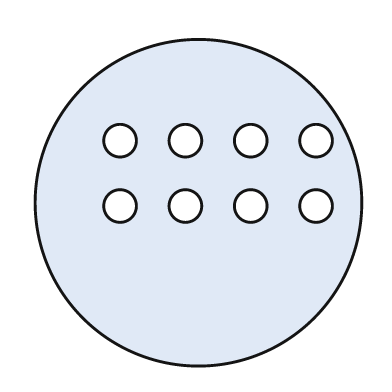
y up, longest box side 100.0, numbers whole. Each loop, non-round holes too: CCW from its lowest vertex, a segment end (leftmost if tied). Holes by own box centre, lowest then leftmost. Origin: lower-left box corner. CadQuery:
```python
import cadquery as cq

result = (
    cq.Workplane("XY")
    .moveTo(50.0, 50.0)
    .circle(50.0)
    .moveTo(26.0, 49.0)
    .circle(5.0)
    .moveTo(46.0, 49.0)
    .circle(5.0)
    .moveTo(66.0, 49.0)
    .circle(5.0)
    .moveTo(86.0, 49.0)
    .circle(5.0)
    .moveTo(26.0, 69.0)
    .circle(5.0)
    .moveTo(46.0, 69.0)
    .circle(5.0)
    .moveTo(66.0, 69.0)
    .circle(5.0)
    .moveTo(86.0, 69.0)
    .circle(5.0)
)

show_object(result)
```